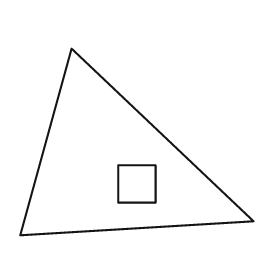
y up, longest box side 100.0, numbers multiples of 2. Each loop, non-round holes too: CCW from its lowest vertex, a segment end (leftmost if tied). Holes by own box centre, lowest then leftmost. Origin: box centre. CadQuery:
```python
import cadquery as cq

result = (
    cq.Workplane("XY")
    .moveTo(-50.0, -40.0)
    .lineTo(50.0, -34.0)
    .lineTo(-28.0, 40.0)
    .close()
    .moveTo(-8.0, -26.0)
    .lineTo(8.0, -26.0)
    .lineTo(8.0, -10.0)
    .lineTo(-8.0, -10.0)
    .close()
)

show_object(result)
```